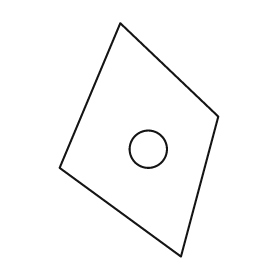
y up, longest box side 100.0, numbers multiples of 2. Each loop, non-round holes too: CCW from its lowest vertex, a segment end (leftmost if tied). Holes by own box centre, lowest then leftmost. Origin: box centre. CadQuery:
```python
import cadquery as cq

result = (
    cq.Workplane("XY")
    .moveTo(18.0, -50.0)
    .lineTo(34.0, 10.0)
    .lineTo(-8.0, 50.0)
    .lineTo(-34.0, -12.0)
    .close()
    .moveTo(4.0, -4.0)
    .circle(8.0)
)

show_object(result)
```